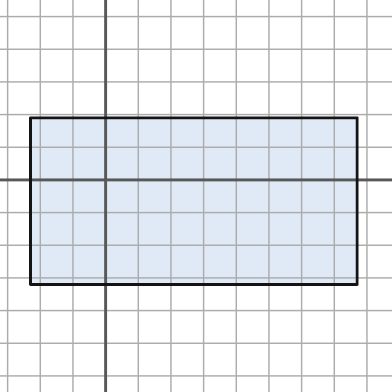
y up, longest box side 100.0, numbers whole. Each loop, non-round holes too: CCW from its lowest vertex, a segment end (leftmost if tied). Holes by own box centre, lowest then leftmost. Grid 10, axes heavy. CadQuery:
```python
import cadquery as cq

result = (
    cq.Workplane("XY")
    .moveTo(-23.0, -32.0)
    .lineTo(77.0, -32.0)
    .lineTo(77.0, 19.0)
    .lineTo(-23.0, 19.0)
    .close()
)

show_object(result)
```